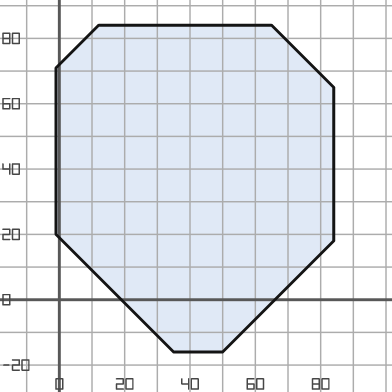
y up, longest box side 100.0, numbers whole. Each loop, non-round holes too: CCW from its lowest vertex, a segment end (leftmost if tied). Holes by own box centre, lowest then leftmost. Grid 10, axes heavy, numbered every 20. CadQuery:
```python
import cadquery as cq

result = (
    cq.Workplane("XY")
    .moveTo(35.0, -16.0)
    .lineTo(50.0, -16.0)
    .lineTo(84.0, 18.0)
    .lineTo(84.0, 65.0)
    .lineTo(65.0, 84.0)
    .lineTo(12.0, 84.0)
    .lineTo(-1.0, 71.0)
    .lineTo(-1.0, 20.0)
    .close()
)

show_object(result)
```